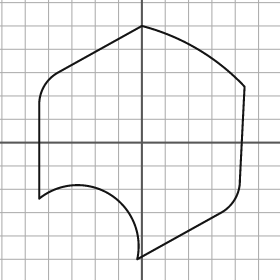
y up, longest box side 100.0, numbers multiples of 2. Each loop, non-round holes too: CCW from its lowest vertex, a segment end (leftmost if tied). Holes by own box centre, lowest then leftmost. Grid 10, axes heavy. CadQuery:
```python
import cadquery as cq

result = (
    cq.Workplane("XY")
    .moveTo(-2.0, -50.0)
    .lineTo(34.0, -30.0)
    .threePointArc((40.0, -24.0), (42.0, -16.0))
    .lineTo(44.0, 24.0)
    .threePointArc((24.0, 40.0), (0.0, 50.0))
    .lineTo(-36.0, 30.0)
    .threePointArc((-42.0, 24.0), (-44.0, 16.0))
    .lineTo(-44.0, -24.0)
    .threePointArc((-14.0, -22.0), (-2.0, -50.0))
    .close()
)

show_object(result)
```